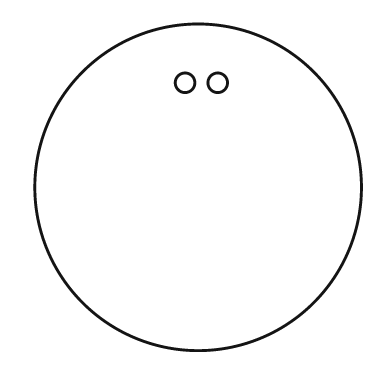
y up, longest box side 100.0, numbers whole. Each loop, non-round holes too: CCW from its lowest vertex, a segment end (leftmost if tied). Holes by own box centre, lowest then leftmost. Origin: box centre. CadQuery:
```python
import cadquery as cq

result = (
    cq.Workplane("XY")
    .moveTo(0.0, 0.0)
    .circle(50.0)
    .moveTo(-4.0, 32.0)
    .circle(3.0)
    .moveTo(6.0, 32.0)
    .circle(3.0)
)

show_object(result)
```